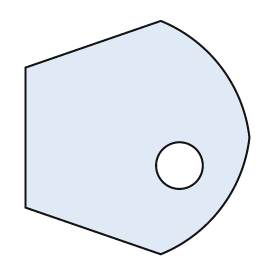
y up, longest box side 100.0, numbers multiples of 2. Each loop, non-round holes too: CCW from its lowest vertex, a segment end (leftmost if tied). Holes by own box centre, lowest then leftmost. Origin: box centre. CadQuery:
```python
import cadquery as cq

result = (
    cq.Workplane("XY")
    .moveTo(10.0, -50.0)
    .threePointArc((36.0, -30.0), (48.0, 0.0))
    .threePointArc((36.0, 30.0), (10.0, 50.0))
    .lineTo(-48.0, 30.0)
    .lineTo(-48.0, -30.0)
    .close()
    .moveTo(18.0, -12.0)
    .circle(10.0)
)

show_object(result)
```